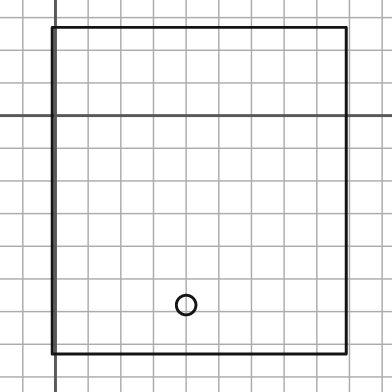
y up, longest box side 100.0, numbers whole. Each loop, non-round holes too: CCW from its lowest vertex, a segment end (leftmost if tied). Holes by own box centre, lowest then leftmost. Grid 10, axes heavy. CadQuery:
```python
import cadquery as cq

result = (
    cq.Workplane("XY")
    .moveTo(-1.0, -73.0)
    .lineTo(89.0, -73.0)
    .lineTo(89.0, 27.0)
    .lineTo(-1.0, 27.0)
    .close()
    .moveTo(40.0, -58.0)
    .circle(3.0)
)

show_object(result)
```